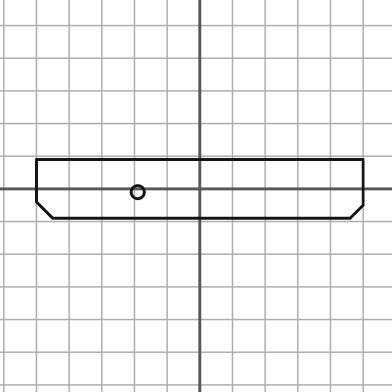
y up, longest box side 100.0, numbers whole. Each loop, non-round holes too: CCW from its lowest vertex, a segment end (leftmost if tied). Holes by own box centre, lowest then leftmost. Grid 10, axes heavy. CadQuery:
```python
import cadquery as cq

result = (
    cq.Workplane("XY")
    .moveTo(-45.0, -9.0)
    .lineTo(46.0, -9.0)
    .lineTo(50.0, -5.0)
    .lineTo(50.0, 9.0)
    .lineTo(-50.0, 9.0)
    .lineTo(-50.0, -4.0)
    .close()
    .moveTo(-19.0, -1.0)
    .circle(2.0)
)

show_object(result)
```